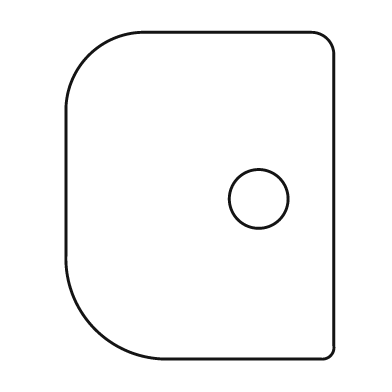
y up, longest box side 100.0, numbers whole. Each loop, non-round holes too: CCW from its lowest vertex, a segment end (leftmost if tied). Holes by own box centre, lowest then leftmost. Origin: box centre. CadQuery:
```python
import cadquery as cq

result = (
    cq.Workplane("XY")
    .moveTo(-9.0, -50.0)
    .lineTo(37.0, -50.0)
    .threePointArc((40.0, -49.0), (41.0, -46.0))
    .lineTo(41.0, 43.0)
    .threePointArc((39.0, 48.0), (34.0, 50.0))
    .lineTo(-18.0, 50.0)
    .threePointArc((-34.0, 43.0), (-41.0, 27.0))
    .lineTo(-41.0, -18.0)
    .threePointArc((-32.0, -41.0), (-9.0, -50.0))
    .close()
    .moveTo(18.0, -1.0)
    .circle(9.0)
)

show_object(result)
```